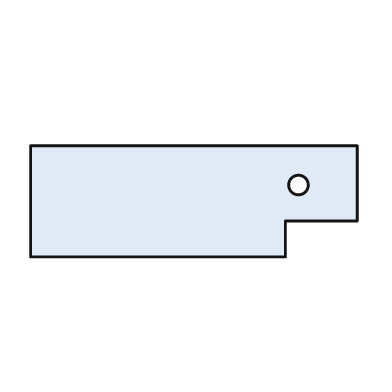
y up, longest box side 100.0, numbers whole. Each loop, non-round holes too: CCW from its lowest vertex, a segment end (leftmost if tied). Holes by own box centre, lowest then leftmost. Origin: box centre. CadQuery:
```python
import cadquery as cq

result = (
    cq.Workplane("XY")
    .moveTo(-50.0, -17.0)
    .lineTo(28.0, -17.0)
    .lineTo(28.0, -6.0)
    .lineTo(50.0, -6.0)
    .lineTo(50.0, 17.0)
    .lineTo(-50.0, 17.0)
    .close()
    .moveTo(32.0, 5.0)
    .circle(3.0)
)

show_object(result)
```